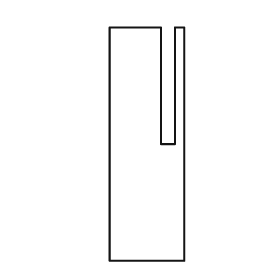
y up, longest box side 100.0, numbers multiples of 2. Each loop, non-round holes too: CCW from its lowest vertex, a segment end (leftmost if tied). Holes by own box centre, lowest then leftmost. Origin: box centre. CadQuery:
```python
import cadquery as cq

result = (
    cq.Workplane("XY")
    .moveTo(-16.0, -50.0)
    .lineTo(16.0, -50.0)
    .lineTo(16.0, 50.0)
    .lineTo(12.0, 50.0)
    .lineTo(12.0, 0.0)
    .lineTo(6.0, 0.0)
    .lineTo(6.0, 50.0)
    .lineTo(-16.0, 50.0)
    .close()
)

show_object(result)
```